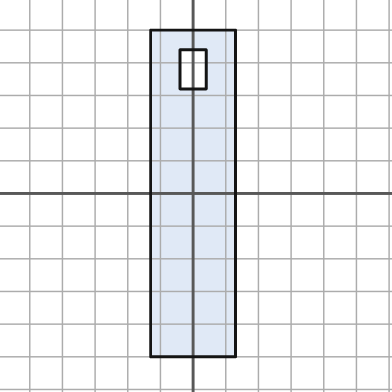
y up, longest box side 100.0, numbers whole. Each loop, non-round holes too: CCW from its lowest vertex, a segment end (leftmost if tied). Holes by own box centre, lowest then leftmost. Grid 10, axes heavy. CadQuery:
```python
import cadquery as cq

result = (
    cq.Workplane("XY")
    .moveTo(-13.0, -50.0)
    .lineTo(13.0, -50.0)
    .lineTo(13.0, 50.0)
    .lineTo(-13.0, 50.0)
    .close()
    .moveTo(-4.0, 32.0)
    .lineTo(4.0, 32.0)
    .lineTo(4.0, 44.0)
    .lineTo(-4.0, 44.0)
    .close()
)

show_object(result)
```